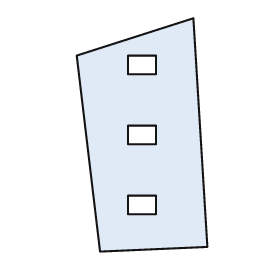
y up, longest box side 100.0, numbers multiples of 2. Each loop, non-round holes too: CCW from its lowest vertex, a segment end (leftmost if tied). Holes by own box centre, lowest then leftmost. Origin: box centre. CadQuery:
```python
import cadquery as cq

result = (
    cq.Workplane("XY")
    .moveTo(-18.0, -50.0)
    .lineTo(28.0, -48.0)
    .lineTo(22.0, 50.0)
    .lineTo(-28.0, 34.0)
    .close()
    .moveTo(-6.0, -34.0)
    .lineTo(6.0, -34.0)
    .lineTo(6.0, -26.0)
    .lineTo(-6.0, -26.0)
    .close()
    .moveTo(-6.0, -4.0)
    .lineTo(6.0, -4.0)
    .lineTo(6.0, 4.0)
    .lineTo(-6.0, 4.0)
    .close()
    .moveTo(-6.0, 26.0)
    .lineTo(6.0, 26.0)
    .lineTo(6.0, 34.0)
    .lineTo(-6.0, 34.0)
    .close()
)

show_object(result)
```